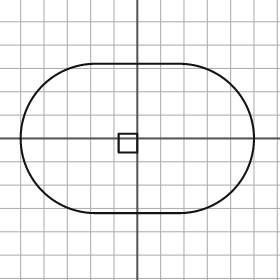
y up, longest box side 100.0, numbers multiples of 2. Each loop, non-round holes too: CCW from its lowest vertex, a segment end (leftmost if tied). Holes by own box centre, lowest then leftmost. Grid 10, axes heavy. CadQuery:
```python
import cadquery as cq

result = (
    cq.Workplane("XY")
    .moveTo(-18.0, -32.0)
    .lineTo(18.0, -32.0)
    .threePointArc((50.0, 0.0), (18.0, 32.0))
    .lineTo(-18.0, 32.0)
    .threePointArc((-50.0, 0.0), (-18.0, -32.0))
    .close()
    .moveTo(-8.0, -6.0)
    .lineTo(0.0, -6.0)
    .lineTo(0.0, 2.0)
    .lineTo(-8.0, 2.0)
    .close()
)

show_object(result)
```